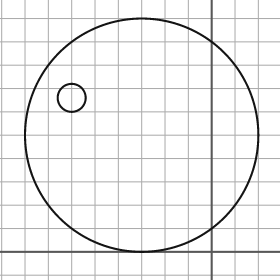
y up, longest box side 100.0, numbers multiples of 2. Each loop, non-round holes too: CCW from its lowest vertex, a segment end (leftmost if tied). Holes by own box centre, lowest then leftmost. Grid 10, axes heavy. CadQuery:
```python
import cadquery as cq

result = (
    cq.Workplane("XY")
    .moveTo(-30.0, 50.0)
    .circle(50.0)
    .moveTo(-60.0, 66.0)
    .circle(6.0)
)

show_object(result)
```